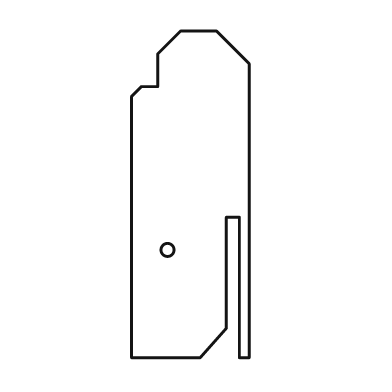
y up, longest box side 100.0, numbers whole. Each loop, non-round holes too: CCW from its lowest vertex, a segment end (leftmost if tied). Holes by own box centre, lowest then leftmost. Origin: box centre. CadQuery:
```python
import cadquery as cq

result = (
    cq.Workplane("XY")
    .moveTo(-18.0, -50.0)
    .lineTo(3.0, -50.0)
    .lineTo(11.0, -41.0)
    .lineTo(11.0, -7.0)
    .lineTo(15.0, -7.0)
    .lineTo(15.0, -50.0)
    .lineTo(18.0, -50.0)
    .lineTo(18.0, 40.0)
    .lineTo(8.0, 50.0)
    .lineTo(-3.0, 50.0)
    .lineTo(-10.0, 43.0)
    .lineTo(-10.0, 33.0)
    .lineTo(-15.0, 33.0)
    .lineTo(-18.0, 30.0)
    .close()
    .moveTo(-7.0, -17.0)
    .circle(2.0)
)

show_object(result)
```